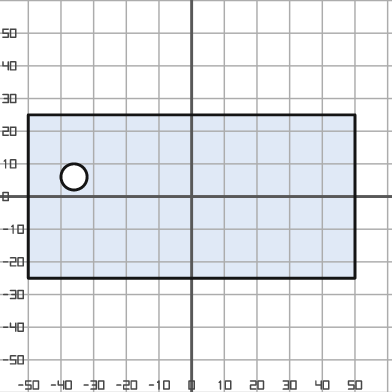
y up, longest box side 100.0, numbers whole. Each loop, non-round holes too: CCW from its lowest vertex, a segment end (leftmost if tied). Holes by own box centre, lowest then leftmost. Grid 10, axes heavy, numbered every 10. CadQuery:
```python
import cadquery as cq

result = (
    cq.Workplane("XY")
    .moveTo(-50.0, -25.0)
    .lineTo(50.0, -25.0)
    .lineTo(50.0, 25.0)
    .lineTo(-50.0, 25.0)
    .close()
    .moveTo(-36.0, 6.0)
    .circle(4.0)
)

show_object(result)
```